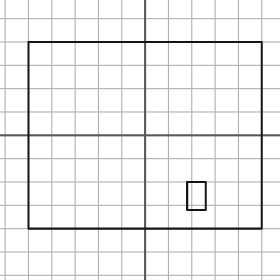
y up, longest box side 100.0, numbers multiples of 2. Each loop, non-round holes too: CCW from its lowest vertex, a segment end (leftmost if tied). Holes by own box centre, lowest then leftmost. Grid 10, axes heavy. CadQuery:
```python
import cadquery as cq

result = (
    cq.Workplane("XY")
    .moveTo(-50.0, -40.0)
    .lineTo(50.0, -40.0)
    .lineTo(50.0, 40.0)
    .lineTo(-50.0, 40.0)
    .close()
    .moveTo(18.0, -32.0)
    .lineTo(26.0, -32.0)
    .lineTo(26.0, -20.0)
    .lineTo(18.0, -20.0)
    .close()
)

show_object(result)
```